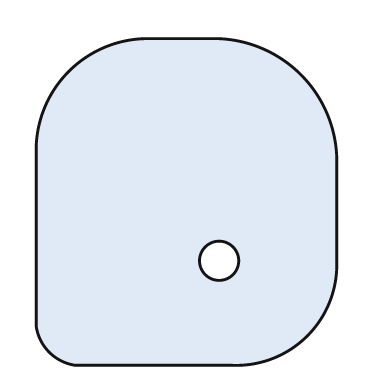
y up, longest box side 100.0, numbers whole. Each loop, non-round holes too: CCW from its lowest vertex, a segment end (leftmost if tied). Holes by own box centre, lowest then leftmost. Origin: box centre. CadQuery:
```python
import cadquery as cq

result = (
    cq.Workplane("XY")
    .moveTo(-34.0, -50.0)
    .lineTo(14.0, -50.0)
    .threePointArc((37.0, -41.0), (46.0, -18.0))
    .lineTo(46.0, 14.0)
    .threePointArc((35.0, 39.0), (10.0, 50.0))
    .lineTo(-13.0, 50.0)
    .threePointArc((-36.0, 40.0), (-46.0, 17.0))
    .lineTo(-46.0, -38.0)
    .threePointArc((-42.0, -46.0), (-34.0, -50.0))
    .close()
    .moveTo(10.0, -18.0)
    .circle(6.0)
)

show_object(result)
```